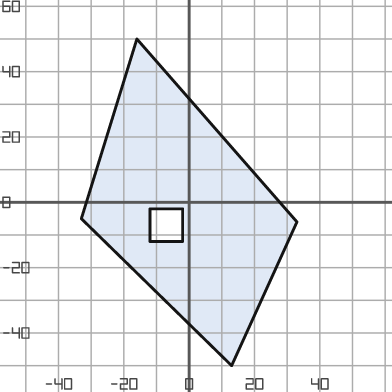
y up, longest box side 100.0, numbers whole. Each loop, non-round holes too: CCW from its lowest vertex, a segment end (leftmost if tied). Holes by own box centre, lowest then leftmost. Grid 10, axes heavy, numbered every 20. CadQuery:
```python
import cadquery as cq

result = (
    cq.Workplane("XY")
    .moveTo(13.0, -50.0)
    .lineTo(33.0, -6.0)
    .lineTo(-16.0, 50.0)
    .lineTo(-33.0, -5.0)
    .close()
    .moveTo(-12.0, -12.0)
    .lineTo(-2.0, -12.0)
    .lineTo(-2.0, -2.0)
    .lineTo(-12.0, -2.0)
    .close()
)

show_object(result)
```